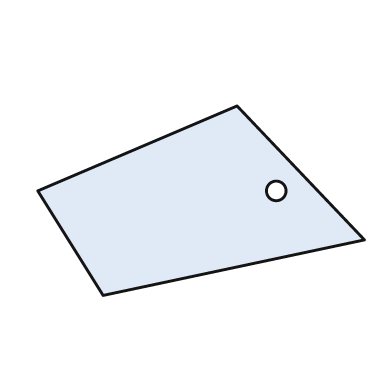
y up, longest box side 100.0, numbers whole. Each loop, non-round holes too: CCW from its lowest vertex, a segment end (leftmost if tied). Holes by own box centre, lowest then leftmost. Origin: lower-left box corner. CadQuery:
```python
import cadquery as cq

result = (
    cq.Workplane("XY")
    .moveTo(20.0, 0.0)
    .lineTo(100.0, 17.0)
    .lineTo(61.0, 58.0)
    .lineTo(0.0, 32.0)
    .close()
    .moveTo(73.0, 32.0)
    .circle(3.0)
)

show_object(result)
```